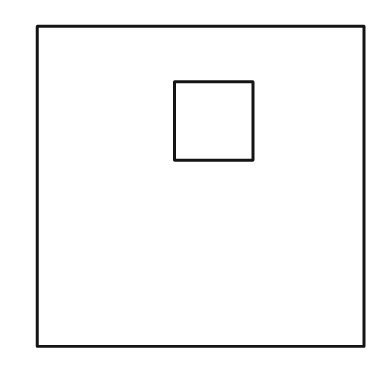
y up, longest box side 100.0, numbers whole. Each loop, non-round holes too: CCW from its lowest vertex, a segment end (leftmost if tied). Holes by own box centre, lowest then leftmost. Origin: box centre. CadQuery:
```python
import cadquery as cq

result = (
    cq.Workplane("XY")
    .moveTo(-50.0, -49.0)
    .lineTo(50.0, -49.0)
    .lineTo(50.0, 49.0)
    .lineTo(-50.0, 49.0)
    .close()
    .moveTo(-8.0, 8.0)
    .lineTo(16.0, 8.0)
    .lineTo(16.0, 32.0)
    .lineTo(-8.0, 32.0)
    .close()
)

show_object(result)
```